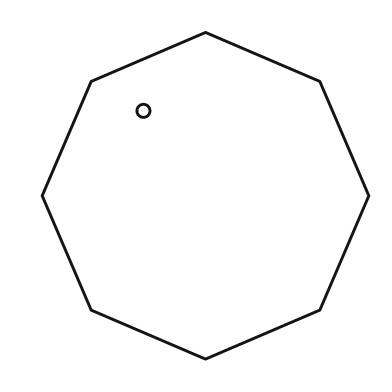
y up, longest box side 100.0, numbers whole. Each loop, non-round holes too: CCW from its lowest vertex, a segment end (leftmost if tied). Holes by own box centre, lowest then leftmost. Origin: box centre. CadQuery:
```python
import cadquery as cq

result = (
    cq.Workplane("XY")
    .moveTo(0.0, -50.0)
    .lineTo(35.0, -35.0)
    .lineTo(50.0, 0.0)
    .lineTo(35.0, 35.0)
    .lineTo(0.0, 50.0)
    .lineTo(-35.0, 35.0)
    .lineTo(-50.0, 0.0)
    .lineTo(-35.0, -35.0)
    .close()
    .moveTo(-19.0, 26.0)
    .circle(2.0)
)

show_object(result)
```